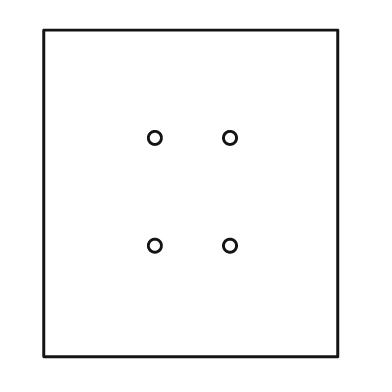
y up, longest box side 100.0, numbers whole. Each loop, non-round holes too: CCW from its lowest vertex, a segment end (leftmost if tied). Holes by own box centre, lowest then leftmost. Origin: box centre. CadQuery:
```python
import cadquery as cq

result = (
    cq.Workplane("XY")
    .moveTo(-45.0, -50.0)
    .lineTo(45.0, -50.0)
    .lineTo(45.0, 50.0)
    .lineTo(-45.0, 50.0)
    .close()
    .moveTo(-11.0, -16.0)
    .circle(2.0)
    .moveTo(12.0, -16.0)
    .circle(2.0)
    .moveTo(-11.0, 17.0)
    .circle(2.0)
    .moveTo(12.0, 17.0)
    .circle(2.0)
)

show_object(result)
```